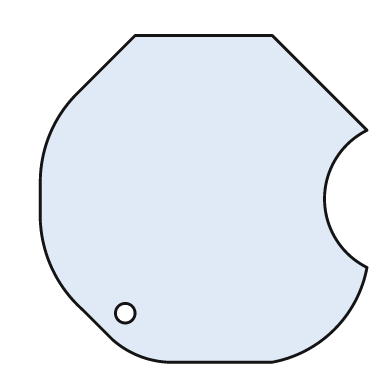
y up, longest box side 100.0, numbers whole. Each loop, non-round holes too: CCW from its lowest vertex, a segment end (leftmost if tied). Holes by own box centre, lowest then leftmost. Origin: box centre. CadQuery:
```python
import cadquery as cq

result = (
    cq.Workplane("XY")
    .moveTo(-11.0, -50.0)
    .lineTo(21.0, -50.0)
    .threePointArc((40.0, -40.0), (50.0, -21.0))
    .threePointArc((37.0, 0.0), (50.0, 21.0))
    .lineTo(21.0, 50.0)
    .lineTo(-21.0, 50.0)
    .lineTo(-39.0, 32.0)
    .threePointArc((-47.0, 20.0), (-50.0, 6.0))
    .lineTo(-50.0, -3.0)
    .threePointArc((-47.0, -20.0), (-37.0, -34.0))
    .lineTo(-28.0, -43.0)
    .threePointArc((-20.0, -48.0), (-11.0, -50.0))
    .close()
    .moveTo(-24.0, -35.0)
    .circle(3.0)
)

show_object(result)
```